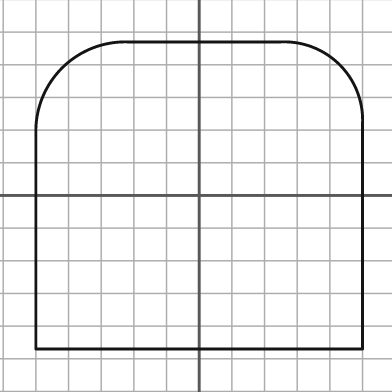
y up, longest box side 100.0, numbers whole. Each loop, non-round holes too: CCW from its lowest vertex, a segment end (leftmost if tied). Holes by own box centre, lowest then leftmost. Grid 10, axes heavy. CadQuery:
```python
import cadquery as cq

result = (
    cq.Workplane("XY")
    .moveTo(-50.0, -47.0)
    .lineTo(50.0, -47.0)
    .lineTo(50.0, 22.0)
    .threePointArc((43.0, 40.0), (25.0, 47.0))
    .lineTo(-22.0, 47.0)
    .threePointArc((-42.0, 39.0), (-50.0, 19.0))
    .close()
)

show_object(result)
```